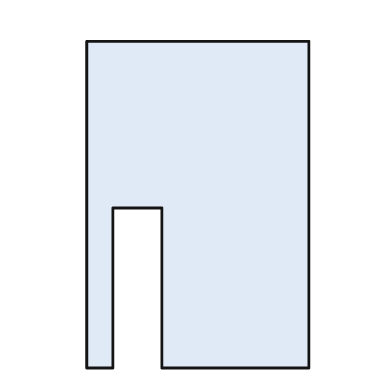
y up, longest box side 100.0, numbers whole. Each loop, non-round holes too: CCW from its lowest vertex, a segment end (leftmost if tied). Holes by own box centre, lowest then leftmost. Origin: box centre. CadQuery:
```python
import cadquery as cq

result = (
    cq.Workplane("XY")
    .moveTo(-34.0, -50.0)
    .lineTo(-26.0, -50.0)
    .lineTo(-26.0, -1.0)
    .lineTo(-11.0, -1.0)
    .lineTo(-11.0, -50.0)
    .lineTo(34.0, -50.0)
    .lineTo(34.0, 50.0)
    .lineTo(-34.0, 50.0)
    .close()
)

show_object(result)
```